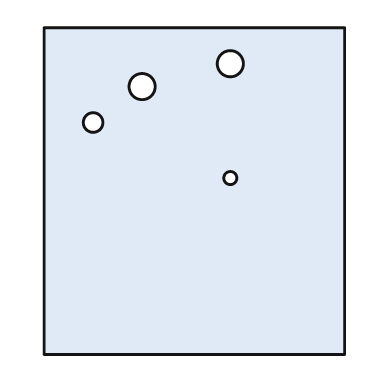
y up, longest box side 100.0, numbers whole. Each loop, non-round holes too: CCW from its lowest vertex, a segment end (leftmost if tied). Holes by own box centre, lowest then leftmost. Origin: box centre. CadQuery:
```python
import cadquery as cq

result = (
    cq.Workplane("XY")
    .moveTo(-46.0, -50.0)
    .lineTo(46.0, -50.0)
    .lineTo(46.0, 50.0)
    .lineTo(-46.0, 50.0)
    .close()
    .moveTo(11.0, 4.0)
    .circle(2.0)
    .moveTo(-31.0, 21.0)
    .circle(3.0)
    .moveTo(-16.0, 32.0)
    .circle(4.0)
    .moveTo(11.0, 39.0)
    .circle(4.0)
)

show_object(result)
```